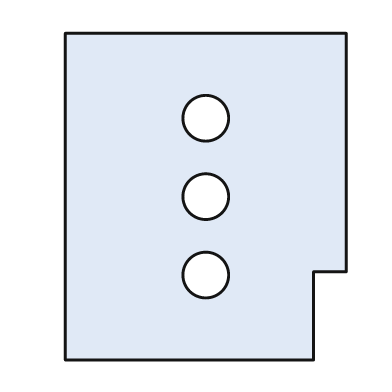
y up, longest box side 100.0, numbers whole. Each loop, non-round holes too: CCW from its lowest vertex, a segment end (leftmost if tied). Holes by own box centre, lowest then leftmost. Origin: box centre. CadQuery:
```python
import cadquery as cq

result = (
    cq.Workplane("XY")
    .moveTo(-43.0, -50.0)
    .lineTo(33.0, -50.0)
    .lineTo(33.0, -23.0)
    .lineTo(43.0, -23.0)
    .lineTo(43.0, 50.0)
    .lineTo(-43.0, 50.0)
    .close()
    .moveTo(0.0, -24.0)
    .circle(7.0)
    .moveTo(0.0, 0.0)
    .circle(7.0)
    .moveTo(0.0, 24.0)
    .circle(7.0)
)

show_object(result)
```